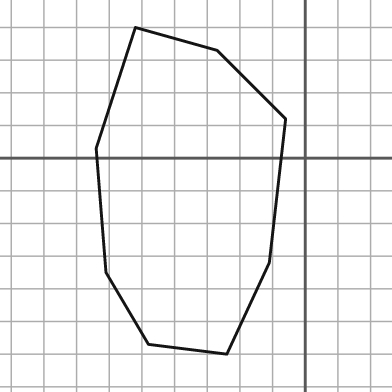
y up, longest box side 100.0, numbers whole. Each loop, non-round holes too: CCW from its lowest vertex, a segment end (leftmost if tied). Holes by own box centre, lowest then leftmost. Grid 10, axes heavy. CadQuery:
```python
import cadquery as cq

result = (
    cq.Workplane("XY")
    .moveTo(-24.0, -60.0)
    .lineTo(-11.0, -32.0)
    .lineTo(-6.0, 12.0)
    .lineTo(-27.0, 33.0)
    .lineTo(-52.0, 40.0)
    .lineTo(-64.0, 3.0)
    .lineTo(-61.0, -35.0)
    .lineTo(-48.0, -57.0)
    .close()
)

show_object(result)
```